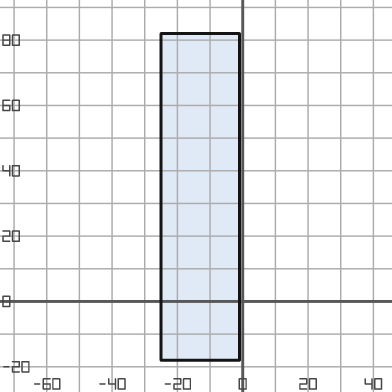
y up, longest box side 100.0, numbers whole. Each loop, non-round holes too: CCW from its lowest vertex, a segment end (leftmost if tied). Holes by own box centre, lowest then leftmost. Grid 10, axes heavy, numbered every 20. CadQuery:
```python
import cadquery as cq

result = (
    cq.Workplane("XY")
    .moveTo(-25.0, -18.0)
    .lineTo(-1.0, -18.0)
    .lineTo(-1.0, 82.0)
    .lineTo(-25.0, 82.0)
    .close()
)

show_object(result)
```